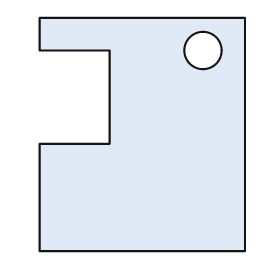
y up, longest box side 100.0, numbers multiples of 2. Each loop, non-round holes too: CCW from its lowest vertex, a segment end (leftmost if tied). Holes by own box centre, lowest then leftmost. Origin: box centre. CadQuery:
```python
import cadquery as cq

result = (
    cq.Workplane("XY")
    .moveTo(-44.0, -50.0)
    .lineTo(44.0, -50.0)
    .lineTo(44.0, 50.0)
    .lineTo(-44.0, 50.0)
    .lineTo(-44.0, 36.0)
    .lineTo(-14.0, 36.0)
    .lineTo(-14.0, -4.0)
    .lineTo(-44.0, -4.0)
    .close()
    .moveTo(26.0, 36.0)
    .circle(8.0)
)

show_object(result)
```